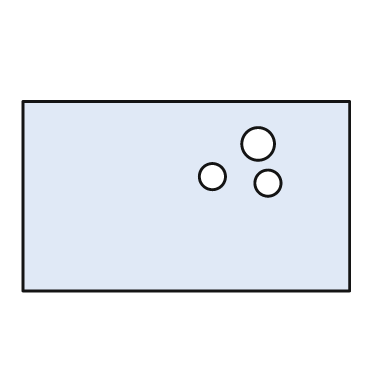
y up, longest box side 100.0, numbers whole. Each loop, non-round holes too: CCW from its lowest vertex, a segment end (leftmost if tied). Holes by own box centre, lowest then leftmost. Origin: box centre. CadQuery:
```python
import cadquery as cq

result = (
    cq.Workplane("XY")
    .moveTo(-50.0, -29.0)
    .lineTo(50.0, -29.0)
    .lineTo(50.0, 29.0)
    .lineTo(-50.0, 29.0)
    .close()
    .moveTo(25.0, 4.0)
    .circle(4.0)
    .moveTo(8.0, 6.0)
    .circle(4.0)
    .moveTo(22.0, 16.0)
    .circle(5.0)
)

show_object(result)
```